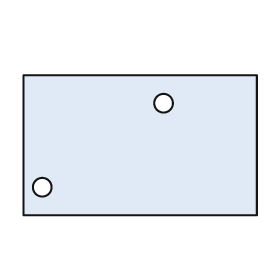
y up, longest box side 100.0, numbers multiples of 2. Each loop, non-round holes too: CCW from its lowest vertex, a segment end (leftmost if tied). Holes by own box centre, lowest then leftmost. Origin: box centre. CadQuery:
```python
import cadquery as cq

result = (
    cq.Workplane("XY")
    .moveTo(-50.0, -30.0)
    .lineTo(50.0, -30.0)
    .lineTo(50.0, 30.0)
    .lineTo(-50.0, 30.0)
    .close()
    .moveTo(-42.0, -18.0)
    .circle(4.0)
    .moveTo(10.0, 18.0)
    .circle(4.0)
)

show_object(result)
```